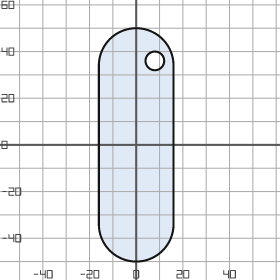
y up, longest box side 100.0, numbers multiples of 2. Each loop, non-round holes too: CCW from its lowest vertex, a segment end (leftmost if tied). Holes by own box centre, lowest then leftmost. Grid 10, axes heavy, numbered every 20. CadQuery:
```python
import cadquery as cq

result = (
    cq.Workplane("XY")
    .moveTo(-16.0, -34.0)
    .threePointArc((0.0, -50.0), (16.0, -34.0))
    .lineTo(16.0, 34.0)
    .threePointArc((0.0, 50.0), (-16.0, 34.0))
    .close()
    .moveTo(8.0, 36.0)
    .circle(4.0)
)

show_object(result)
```